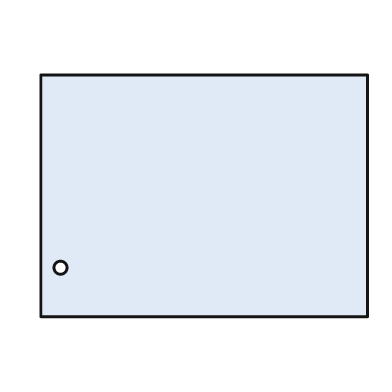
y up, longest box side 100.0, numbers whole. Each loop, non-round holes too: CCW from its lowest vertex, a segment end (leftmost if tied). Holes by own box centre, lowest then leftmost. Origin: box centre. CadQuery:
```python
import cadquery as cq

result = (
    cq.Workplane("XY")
    .moveTo(-50.0, -37.0)
    .lineTo(50.0, -37.0)
    .lineTo(50.0, 37.0)
    .lineTo(-50.0, 37.0)
    .close()
    .moveTo(-44.0, -22.0)
    .circle(2.0)
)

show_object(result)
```